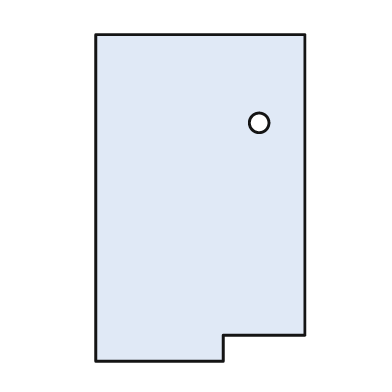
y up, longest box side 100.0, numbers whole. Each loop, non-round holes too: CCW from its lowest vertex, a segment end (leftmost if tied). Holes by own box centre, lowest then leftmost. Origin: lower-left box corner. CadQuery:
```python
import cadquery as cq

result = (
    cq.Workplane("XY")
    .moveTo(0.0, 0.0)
    .lineTo(39.0, 0.0)
    .lineTo(39.0, 8.0)
    .lineTo(64.0, 8.0)
    .lineTo(64.0, 100.0)
    .lineTo(0.0, 100.0)
    .close()
    .moveTo(50.0, 73.0)
    .circle(3.0)
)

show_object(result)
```